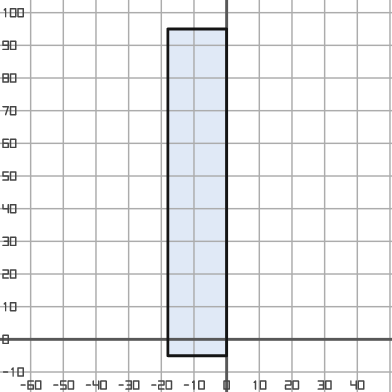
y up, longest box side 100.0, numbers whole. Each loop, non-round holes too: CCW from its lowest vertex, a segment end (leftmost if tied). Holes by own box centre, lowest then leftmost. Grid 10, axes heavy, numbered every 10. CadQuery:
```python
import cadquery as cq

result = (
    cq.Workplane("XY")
    .moveTo(-18.0, -5.0)
    .lineTo(0.0, -5.0)
    .lineTo(0.0, 95.0)
    .lineTo(-18.0, 95.0)
    .close()
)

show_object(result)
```